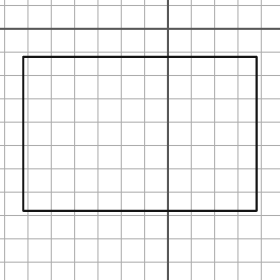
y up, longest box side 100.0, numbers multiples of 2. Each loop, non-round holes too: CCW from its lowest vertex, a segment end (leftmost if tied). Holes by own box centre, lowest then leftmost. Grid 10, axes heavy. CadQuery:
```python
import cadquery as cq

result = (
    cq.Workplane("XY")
    .moveTo(-62.0, -78.0)
    .lineTo(38.0, -78.0)
    .lineTo(38.0, -12.0)
    .lineTo(-62.0, -12.0)
    .close()
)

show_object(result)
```